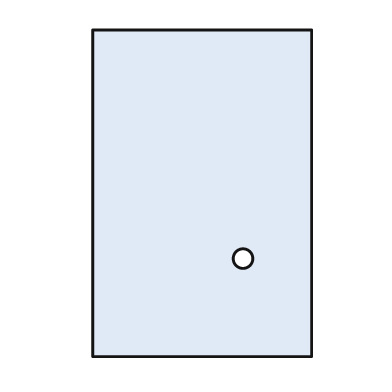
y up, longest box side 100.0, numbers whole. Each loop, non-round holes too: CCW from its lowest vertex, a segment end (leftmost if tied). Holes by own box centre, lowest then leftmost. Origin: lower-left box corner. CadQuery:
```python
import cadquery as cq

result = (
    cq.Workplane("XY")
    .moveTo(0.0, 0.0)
    .lineTo(67.0, 0.0)
    .lineTo(67.0, 100.0)
    .lineTo(0.0, 100.0)
    .close()
    .moveTo(46.0, 30.0)
    .circle(3.0)
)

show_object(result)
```